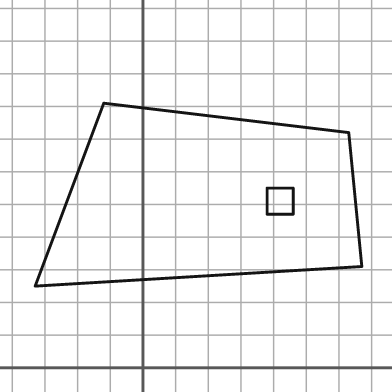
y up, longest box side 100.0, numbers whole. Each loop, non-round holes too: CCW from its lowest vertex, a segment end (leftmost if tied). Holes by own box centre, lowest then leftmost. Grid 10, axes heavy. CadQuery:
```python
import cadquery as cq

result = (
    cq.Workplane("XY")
    .moveTo(-33.0, 25.0)
    .lineTo(67.0, 31.0)
    .lineTo(63.0, 72.0)
    .lineTo(-12.0, 81.0)
    .close()
    .moveTo(38.0, 47.0)
    .lineTo(46.0, 47.0)
    .lineTo(46.0, 55.0)
    .lineTo(38.0, 55.0)
    .close()
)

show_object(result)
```